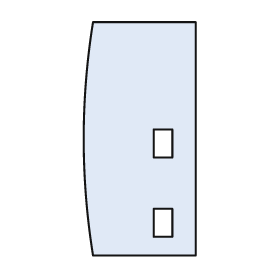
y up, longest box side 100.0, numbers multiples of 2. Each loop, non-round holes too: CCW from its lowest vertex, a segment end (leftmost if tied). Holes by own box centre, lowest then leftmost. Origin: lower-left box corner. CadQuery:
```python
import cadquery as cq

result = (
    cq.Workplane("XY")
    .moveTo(4.0, 0.0)
    .lineTo(48.0, 0.0)
    .lineTo(48.0, 100.0)
    .lineTo(4.0, 100.0)
    .threePointArc((0.0, 50.0), (4.0, 0.0))
    .close()
    .moveTo(30.0, 8.0)
    .lineTo(38.0, 8.0)
    .lineTo(38.0, 20.0)
    .lineTo(30.0, 20.0)
    .close()
    .moveTo(30.0, 42.0)
    .lineTo(38.0, 42.0)
    .lineTo(38.0, 54.0)
    .lineTo(30.0, 54.0)
    .close()
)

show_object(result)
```